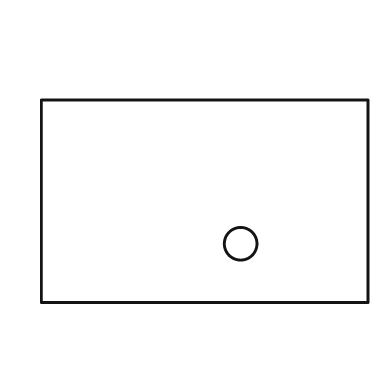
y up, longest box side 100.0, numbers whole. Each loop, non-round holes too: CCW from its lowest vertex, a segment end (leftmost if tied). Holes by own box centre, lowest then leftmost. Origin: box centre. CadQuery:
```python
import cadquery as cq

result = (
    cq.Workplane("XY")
    .moveTo(-50.0, -31.0)
    .lineTo(50.0, -31.0)
    .lineTo(50.0, 31.0)
    .lineTo(-50.0, 31.0)
    .close()
    .moveTo(11.0, -13.0)
    .circle(5.0)
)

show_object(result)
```